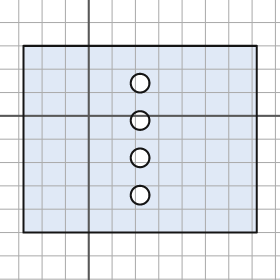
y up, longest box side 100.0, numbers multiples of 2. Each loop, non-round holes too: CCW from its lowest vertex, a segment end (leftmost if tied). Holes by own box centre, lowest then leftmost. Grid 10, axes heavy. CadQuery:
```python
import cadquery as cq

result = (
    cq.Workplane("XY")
    .moveTo(-28.0, -50.0)
    .lineTo(72.0, -50.0)
    .lineTo(72.0, 30.0)
    .lineTo(-28.0, 30.0)
    .close()
    .moveTo(22.0, -34.0)
    .circle(4.0)
    .moveTo(22.0, -18.0)
    .circle(4.0)
    .moveTo(22.0, -2.0)
    .circle(4.0)
    .moveTo(22.0, 14.0)
    .circle(4.0)
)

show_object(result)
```